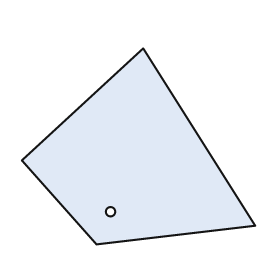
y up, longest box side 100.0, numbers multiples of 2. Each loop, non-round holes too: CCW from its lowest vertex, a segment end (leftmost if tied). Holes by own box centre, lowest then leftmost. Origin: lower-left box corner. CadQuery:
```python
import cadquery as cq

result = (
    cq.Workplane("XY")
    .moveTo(32.0, 0.0)
    .lineTo(100.0, 8.0)
    .lineTo(52.0, 84.0)
    .lineTo(0.0, 36.0)
    .close()
    .moveTo(38.0, 14.0)
    .circle(2.0)
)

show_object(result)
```